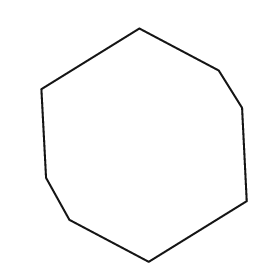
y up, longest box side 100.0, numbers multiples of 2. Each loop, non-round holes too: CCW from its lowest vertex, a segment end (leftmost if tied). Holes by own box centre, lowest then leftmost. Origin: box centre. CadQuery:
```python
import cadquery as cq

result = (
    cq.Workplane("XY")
    .moveTo(2.0, -50.0)
    .lineTo(44.0, -24.0)
    .lineTo(42.0, 16.0)
    .lineTo(32.0, 32.0)
    .lineTo(-2.0, 50.0)
    .lineTo(-44.0, 24.0)
    .lineTo(-42.0, -14.0)
    .lineTo(-32.0, -32.0)
    .close()
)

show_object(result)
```